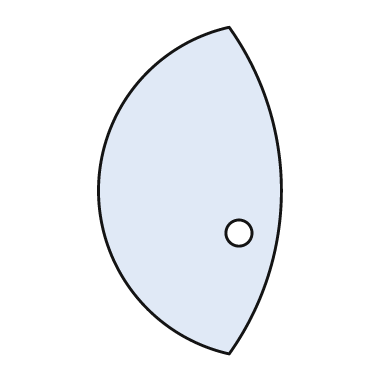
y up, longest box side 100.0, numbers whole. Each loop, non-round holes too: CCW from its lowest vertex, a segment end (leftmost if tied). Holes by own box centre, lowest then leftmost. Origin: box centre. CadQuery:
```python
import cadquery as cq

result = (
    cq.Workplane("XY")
    .moveTo(12.0, -50.0)
    .threePointArc((28.0, 0.0), (12.0, 50.0))
    .threePointArc((-28.0, 0.0), (12.0, -50.0))
    .close()
    .moveTo(15.0, -13.0)
    .circle(4.0)
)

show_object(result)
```